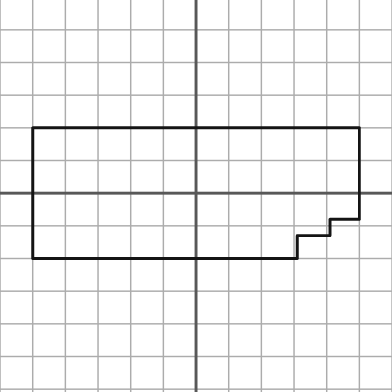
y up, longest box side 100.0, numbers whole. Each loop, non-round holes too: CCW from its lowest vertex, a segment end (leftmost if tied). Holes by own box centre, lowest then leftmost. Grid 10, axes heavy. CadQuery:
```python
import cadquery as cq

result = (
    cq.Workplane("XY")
    .moveTo(-50.0, -20.0)
    .lineTo(31.0, -20.0)
    .lineTo(31.0, -13.0)
    .lineTo(41.0, -13.0)
    .lineTo(41.0, -8.0)
    .lineTo(50.0, -8.0)
    .lineTo(50.0, 20.0)
    .lineTo(-50.0, 20.0)
    .close()
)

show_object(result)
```